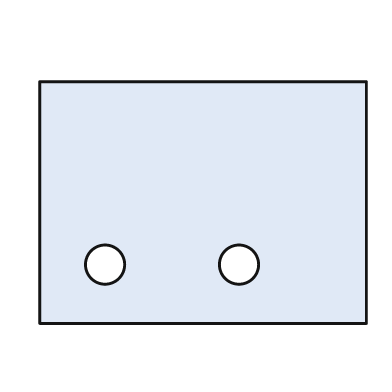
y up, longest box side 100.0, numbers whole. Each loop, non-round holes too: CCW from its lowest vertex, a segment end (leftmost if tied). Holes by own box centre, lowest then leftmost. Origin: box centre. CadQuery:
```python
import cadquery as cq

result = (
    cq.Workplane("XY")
    .moveTo(-50.0, -37.0)
    .lineTo(50.0, -37.0)
    .lineTo(50.0, 37.0)
    .lineTo(-50.0, 37.0)
    .close()
    .moveTo(-30.0, -19.0)
    .circle(6.0)
    .moveTo(11.0, -19.0)
    .circle(6.0)
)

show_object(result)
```